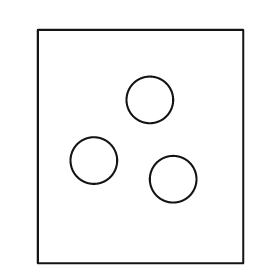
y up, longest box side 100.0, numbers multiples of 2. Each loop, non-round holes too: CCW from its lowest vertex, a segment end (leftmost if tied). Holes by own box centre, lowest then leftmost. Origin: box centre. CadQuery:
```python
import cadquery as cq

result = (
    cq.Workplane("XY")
    .moveTo(-44.0, -50.0)
    .lineTo(44.0, -50.0)
    .lineTo(44.0, 50.0)
    .lineTo(-44.0, 50.0)
    .close()
    .moveTo(14.0, -14.0)
    .circle(10.0)
    .moveTo(-20.0, -6.0)
    .circle(10.0)
    .moveTo(4.0, 20.0)
    .circle(10.0)
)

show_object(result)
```